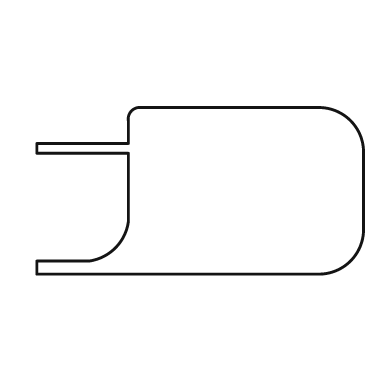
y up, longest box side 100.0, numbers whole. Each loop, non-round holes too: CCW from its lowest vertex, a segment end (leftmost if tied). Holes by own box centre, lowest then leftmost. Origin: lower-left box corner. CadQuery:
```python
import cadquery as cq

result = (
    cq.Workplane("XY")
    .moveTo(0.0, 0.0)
    .lineTo(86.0, 0.0)
    .threePointArc((96.0, 4.0), (100.0, 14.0))
    .lineTo(100.0, 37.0)
    .threePointArc((96.0, 47.0), (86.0, 51.0))
    .lineTo(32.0, 51.0)
    .threePointArc((29.0, 50.0), (28.0, 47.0))
    .lineTo(28.0, 40.0)
    .lineTo(0.0, 40.0)
    .lineTo(0.0, 37.0)
    .lineTo(28.0, 37.0)
    .lineTo(28.0, 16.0)
    .threePointArc((24.0, 8.0), (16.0, 4.0))
    .lineTo(0.0, 4.0)
    .close()
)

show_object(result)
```